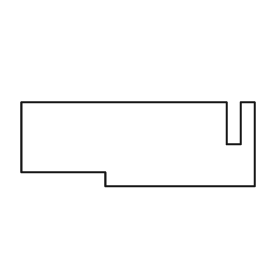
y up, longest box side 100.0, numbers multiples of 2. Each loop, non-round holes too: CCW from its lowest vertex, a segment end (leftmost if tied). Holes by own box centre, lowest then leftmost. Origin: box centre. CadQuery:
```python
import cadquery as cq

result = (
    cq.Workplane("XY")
    .moveTo(-14.0, -18.0)
    .lineTo(50.0, -18.0)
    .lineTo(50.0, 18.0)
    .lineTo(44.0, 18.0)
    .lineTo(44.0, 0.0)
    .lineTo(38.0, 0.0)
    .lineTo(38.0, 18.0)
    .lineTo(-50.0, 18.0)
    .lineTo(-50.0, -12.0)
    .lineTo(-14.0, -12.0)
    .close()
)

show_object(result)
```